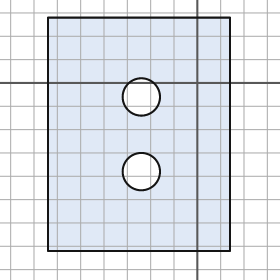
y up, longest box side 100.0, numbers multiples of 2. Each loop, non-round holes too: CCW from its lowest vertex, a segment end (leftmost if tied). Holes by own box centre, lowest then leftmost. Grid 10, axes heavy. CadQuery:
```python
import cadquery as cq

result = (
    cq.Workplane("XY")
    .moveTo(-64.0, -72.0)
    .lineTo(14.0, -72.0)
    .lineTo(14.0, 28.0)
    .lineTo(-64.0, 28.0)
    .close()
    .moveTo(-24.0, -38.0)
    .circle(8.0)
    .moveTo(-24.0, -6.0)
    .circle(8.0)
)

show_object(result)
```